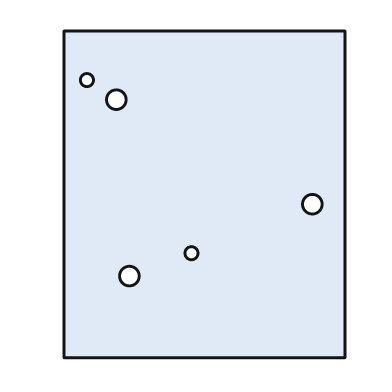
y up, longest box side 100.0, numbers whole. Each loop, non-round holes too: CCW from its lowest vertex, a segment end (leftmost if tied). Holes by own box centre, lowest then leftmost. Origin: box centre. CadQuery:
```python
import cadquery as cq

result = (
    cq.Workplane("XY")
    .moveTo(-43.0, -50.0)
    .lineTo(43.0, -50.0)
    .lineTo(43.0, 50.0)
    .lineTo(-43.0, 50.0)
    .close()
    .moveTo(-23.0, -25.0)
    .circle(3.0)
    .moveTo(-4.0, -18.0)
    .circle(2.0)
    .moveTo(33.0, -3.0)
    .circle(3.0)
    .moveTo(-27.0, 29.0)
    .circle(3.0)
    .moveTo(-36.0, 35.0)
    .circle(2.0)
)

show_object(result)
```